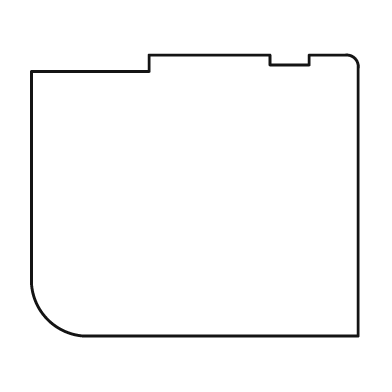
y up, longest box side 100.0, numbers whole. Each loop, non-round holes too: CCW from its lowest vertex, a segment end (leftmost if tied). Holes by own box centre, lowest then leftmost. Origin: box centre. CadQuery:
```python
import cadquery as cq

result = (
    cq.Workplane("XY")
    .moveTo(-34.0, -43.0)
    .lineTo(50.0, -43.0)
    .lineTo(50.0, 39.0)
    .threePointArc((49.0, 42.0), (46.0, 43.0))
    .lineTo(35.0, 43.0)
    .lineTo(35.0, 40.0)
    .lineTo(23.0, 40.0)
    .lineTo(23.0, 43.0)
    .lineTo(-14.0, 43.0)
    .lineTo(-14.0, 38.0)
    .lineTo(-50.0, 38.0)
    .lineTo(-50.0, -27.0)
    .threePointArc((-45.0, -38.0), (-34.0, -43.0))
    .close()
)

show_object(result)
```